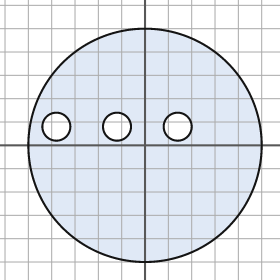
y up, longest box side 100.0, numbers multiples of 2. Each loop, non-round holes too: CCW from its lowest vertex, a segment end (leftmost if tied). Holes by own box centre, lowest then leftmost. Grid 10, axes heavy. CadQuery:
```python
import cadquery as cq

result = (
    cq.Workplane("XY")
    .moveTo(0.0, 0.0)
    .circle(50.0)
    .moveTo(-38.0, 8.0)
    .circle(6.0)
    .moveTo(-12.0, 8.0)
    .circle(6.0)
    .moveTo(14.0, 8.0)
    .circle(6.0)
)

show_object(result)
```